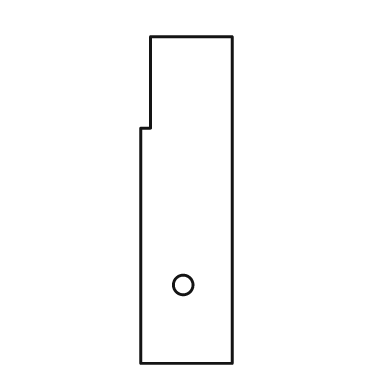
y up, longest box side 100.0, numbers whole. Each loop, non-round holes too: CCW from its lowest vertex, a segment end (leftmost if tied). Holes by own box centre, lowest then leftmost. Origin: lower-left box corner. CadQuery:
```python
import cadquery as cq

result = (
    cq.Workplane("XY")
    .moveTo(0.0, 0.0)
    .lineTo(28.0, 0.0)
    .lineTo(28.0, 100.0)
    .lineTo(3.0, 100.0)
    .lineTo(3.0, 72.0)
    .lineTo(0.0, 72.0)
    .close()
    .moveTo(13.0, 24.0)
    .circle(3.0)
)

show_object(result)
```